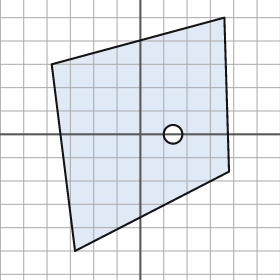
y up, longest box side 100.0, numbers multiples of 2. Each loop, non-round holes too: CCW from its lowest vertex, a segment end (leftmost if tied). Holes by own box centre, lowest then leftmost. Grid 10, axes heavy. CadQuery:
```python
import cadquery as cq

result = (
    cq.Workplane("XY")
    .moveTo(-28.0, -50.0)
    .lineTo(38.0, -16.0)
    .lineTo(36.0, 50.0)
    .lineTo(-38.0, 30.0)
    .close()
    .moveTo(14.0, 0.0)
    .circle(4.0)
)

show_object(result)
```